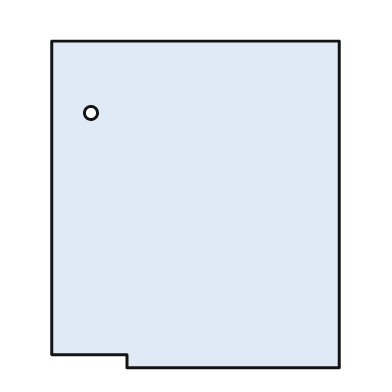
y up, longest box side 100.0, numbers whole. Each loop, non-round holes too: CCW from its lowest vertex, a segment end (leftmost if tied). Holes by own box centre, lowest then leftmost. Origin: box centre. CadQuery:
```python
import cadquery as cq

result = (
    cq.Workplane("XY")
    .moveTo(-21.0, -50.0)
    .lineTo(44.0, -50.0)
    .lineTo(44.0, 50.0)
    .lineTo(-44.0, 50.0)
    .lineTo(-44.0, -46.0)
    .lineTo(-21.0, -46.0)
    .close()
    .moveTo(-32.0, 28.0)
    .circle(2.0)
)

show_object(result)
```